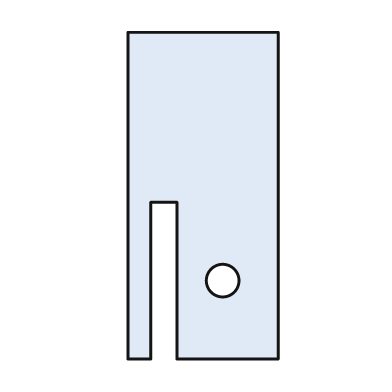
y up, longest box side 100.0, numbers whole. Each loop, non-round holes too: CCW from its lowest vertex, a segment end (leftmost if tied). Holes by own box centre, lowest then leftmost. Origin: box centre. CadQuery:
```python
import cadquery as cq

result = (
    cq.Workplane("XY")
    .moveTo(-23.0, -50.0)
    .lineTo(-16.0, -50.0)
    .lineTo(-16.0, -2.0)
    .lineTo(-8.0, -2.0)
    .lineTo(-8.0, -50.0)
    .lineTo(23.0, -50.0)
    .lineTo(23.0, 50.0)
    .lineTo(-23.0, 50.0)
    .close()
    .moveTo(6.0, -26.0)
    .circle(5.0)
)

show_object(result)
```